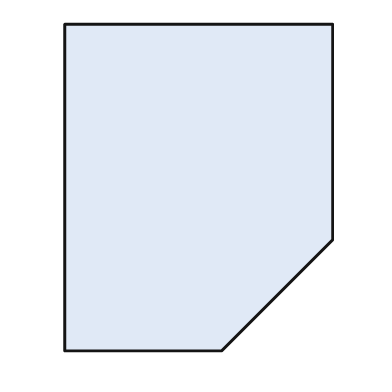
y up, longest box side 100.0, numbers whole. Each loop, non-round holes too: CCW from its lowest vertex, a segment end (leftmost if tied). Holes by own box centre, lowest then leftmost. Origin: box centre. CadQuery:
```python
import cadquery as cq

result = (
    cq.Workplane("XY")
    .moveTo(-41.0, -50.0)
    .lineTo(7.0, -50.0)
    .lineTo(41.0, -16.0)
    .lineTo(41.0, 50.0)
    .lineTo(-41.0, 50.0)
    .close()
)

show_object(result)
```